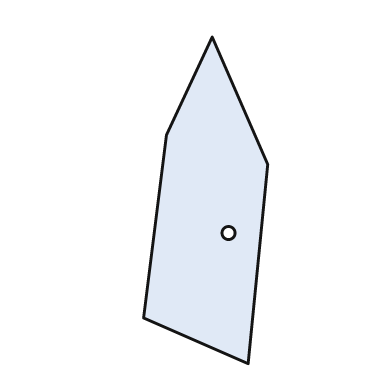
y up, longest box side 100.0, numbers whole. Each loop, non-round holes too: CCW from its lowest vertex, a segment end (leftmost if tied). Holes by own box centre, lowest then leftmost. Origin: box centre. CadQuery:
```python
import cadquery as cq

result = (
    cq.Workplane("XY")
    .moveTo(13.0, -50.0)
    .lineTo(19.0, 11.0)
    .lineTo(2.0, 50.0)
    .lineTo(-12.0, 20.0)
    .lineTo(-19.0, -36.0)
    .close()
    .moveTo(7.0, -10.0)
    .circle(2.0)
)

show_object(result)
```